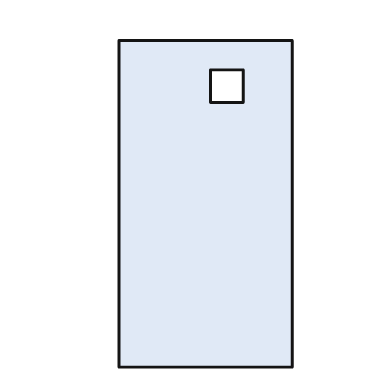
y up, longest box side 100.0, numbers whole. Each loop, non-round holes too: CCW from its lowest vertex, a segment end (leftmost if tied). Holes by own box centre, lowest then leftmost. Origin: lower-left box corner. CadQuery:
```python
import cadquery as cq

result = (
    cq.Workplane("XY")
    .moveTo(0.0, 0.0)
    .lineTo(53.0, 0.0)
    .lineTo(53.0, 100.0)
    .lineTo(0.0, 100.0)
    .close()
    .moveTo(28.0, 81.0)
    .lineTo(38.0, 81.0)
    .lineTo(38.0, 91.0)
    .lineTo(28.0, 91.0)
    .close()
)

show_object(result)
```